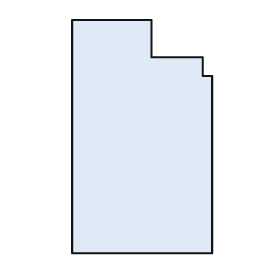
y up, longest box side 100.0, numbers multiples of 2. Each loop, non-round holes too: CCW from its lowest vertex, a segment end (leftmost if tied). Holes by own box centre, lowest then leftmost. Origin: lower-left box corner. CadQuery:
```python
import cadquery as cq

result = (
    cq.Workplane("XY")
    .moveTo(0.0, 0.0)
    .lineTo(60.0, 0.0)
    .lineTo(60.0, 76.0)
    .lineTo(56.0, 76.0)
    .lineTo(56.0, 84.0)
    .lineTo(34.0, 84.0)
    .lineTo(34.0, 100.0)
    .lineTo(0.0, 100.0)
    .close()
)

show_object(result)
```